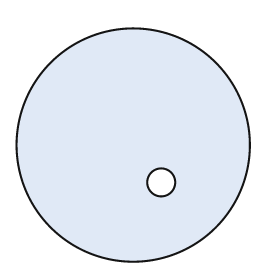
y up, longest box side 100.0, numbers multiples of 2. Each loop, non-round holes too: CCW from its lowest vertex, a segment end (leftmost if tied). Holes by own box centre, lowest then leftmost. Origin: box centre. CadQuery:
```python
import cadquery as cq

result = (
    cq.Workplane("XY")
    .moveTo(0.0, 0.0)
    .circle(50.0)
    .moveTo(12.0, -16.0)
    .circle(6.0)
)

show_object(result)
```